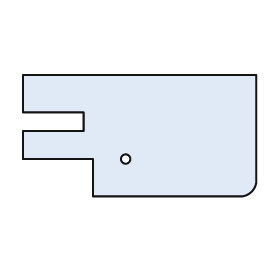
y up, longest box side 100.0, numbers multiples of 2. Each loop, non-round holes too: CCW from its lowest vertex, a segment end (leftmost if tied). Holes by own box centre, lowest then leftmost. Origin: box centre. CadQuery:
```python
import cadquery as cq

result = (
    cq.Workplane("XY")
    .moveTo(-20.0, -26.0)
    .lineTo(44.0, -26.0)
    .threePointArc((48.0, -24.0), (50.0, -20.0))
    .lineTo(50.0, 26.0)
    .lineTo(-50.0, 26.0)
    .lineTo(-50.0, 10.0)
    .lineTo(-24.0, 10.0)
    .lineTo(-24.0, 2.0)
    .lineTo(-50.0, 2.0)
    .lineTo(-50.0, -10.0)
    .lineTo(-20.0, -10.0)
    .close()
    .moveTo(-6.0, -10.0)
    .circle(2.0)
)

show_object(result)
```